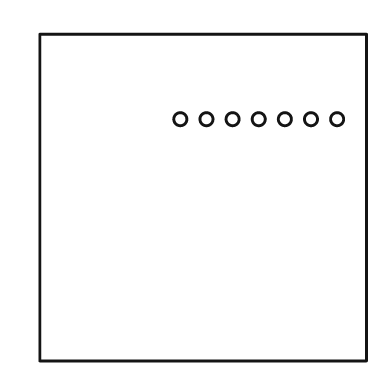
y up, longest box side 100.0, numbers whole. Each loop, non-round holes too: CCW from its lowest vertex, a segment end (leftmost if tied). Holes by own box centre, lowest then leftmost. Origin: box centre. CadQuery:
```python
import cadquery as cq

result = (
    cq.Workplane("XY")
    .moveTo(-50.0, -50.0)
    .lineTo(50.0, -50.0)
    .lineTo(50.0, 50.0)
    .lineTo(-50.0, 50.0)
    .close()
    .moveTo(-7.0, 24.0)
    .circle(2.0)
    .moveTo(1.0, 24.0)
    .circle(2.0)
    .moveTo(9.0, 24.0)
    .circle(2.0)
    .moveTo(17.0, 24.0)
    .circle(2.0)
    .moveTo(25.0, 24.0)
    .circle(2.0)
    .moveTo(33.0, 24.0)
    .circle(2.0)
    .moveTo(41.0, 24.0)
    .circle(2.0)
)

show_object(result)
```